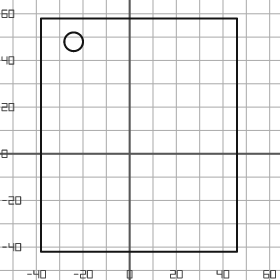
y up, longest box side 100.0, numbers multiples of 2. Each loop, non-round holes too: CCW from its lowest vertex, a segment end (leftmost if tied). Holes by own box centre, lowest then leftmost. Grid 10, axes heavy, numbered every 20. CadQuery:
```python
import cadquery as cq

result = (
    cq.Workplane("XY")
    .moveTo(-38.0, -42.0)
    .lineTo(46.0, -42.0)
    .lineTo(46.0, 58.0)
    .lineTo(-38.0, 58.0)
    .close()
    .moveTo(-24.0, 48.0)
    .circle(4.0)
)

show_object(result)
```